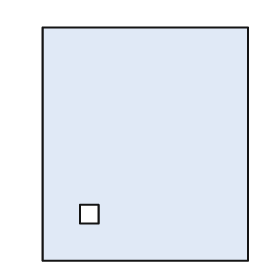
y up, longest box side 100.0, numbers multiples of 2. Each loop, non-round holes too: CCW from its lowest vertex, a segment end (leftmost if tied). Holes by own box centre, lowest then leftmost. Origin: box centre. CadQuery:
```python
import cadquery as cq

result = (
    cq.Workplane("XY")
    .moveTo(-44.0, -50.0)
    .lineTo(44.0, -50.0)
    .lineTo(44.0, 50.0)
    .lineTo(-44.0, 50.0)
    .close()
    .moveTo(-28.0, -34.0)
    .lineTo(-20.0, -34.0)
    .lineTo(-20.0, -26.0)
    .lineTo(-28.0, -26.0)
    .close()
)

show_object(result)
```